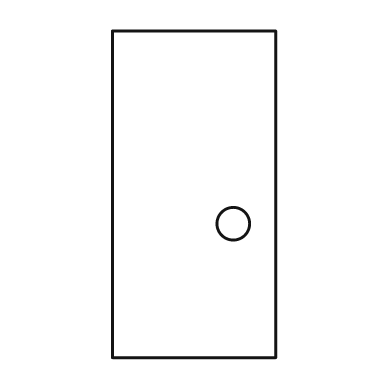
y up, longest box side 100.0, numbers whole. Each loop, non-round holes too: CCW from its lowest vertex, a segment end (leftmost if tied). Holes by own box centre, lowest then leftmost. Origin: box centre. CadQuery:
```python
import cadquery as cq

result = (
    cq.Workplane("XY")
    .moveTo(-25.0, -50.0)
    .lineTo(25.0, -50.0)
    .lineTo(25.0, 50.0)
    .lineTo(-25.0, 50.0)
    .close()
    .moveTo(12.0, -9.0)
    .circle(5.0)
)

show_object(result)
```